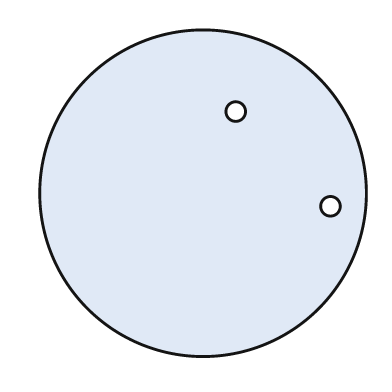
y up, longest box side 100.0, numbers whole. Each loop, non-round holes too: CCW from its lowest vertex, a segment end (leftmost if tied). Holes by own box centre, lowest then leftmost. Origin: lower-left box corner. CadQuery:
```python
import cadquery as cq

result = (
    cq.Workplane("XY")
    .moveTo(50.0, 50.0)
    .circle(50.0)
    .moveTo(89.0, 46.0)
    .circle(3.0)
    .moveTo(60.0, 75.0)
    .circle(3.0)
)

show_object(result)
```